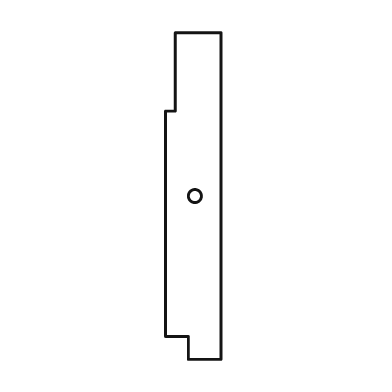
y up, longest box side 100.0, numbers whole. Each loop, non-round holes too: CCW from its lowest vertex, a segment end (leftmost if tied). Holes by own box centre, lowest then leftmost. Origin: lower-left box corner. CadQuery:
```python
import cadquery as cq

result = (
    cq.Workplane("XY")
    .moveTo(7.0, 0.0)
    .lineTo(17.0, 0.0)
    .lineTo(17.0, 100.0)
    .lineTo(3.0, 100.0)
    .lineTo(3.0, 76.0)
    .lineTo(0.0, 76.0)
    .lineTo(0.0, 7.0)
    .lineTo(7.0, 7.0)
    .close()
    .moveTo(9.0, 50.0)
    .circle(2.0)
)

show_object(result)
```